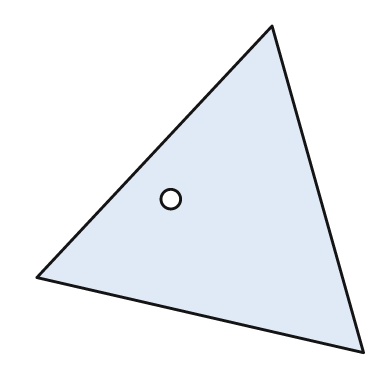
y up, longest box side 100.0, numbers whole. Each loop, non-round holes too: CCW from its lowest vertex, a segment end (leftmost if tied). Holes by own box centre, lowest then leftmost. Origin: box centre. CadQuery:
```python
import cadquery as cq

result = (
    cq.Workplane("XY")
    .moveTo(50.0, -50.0)
    .lineTo(22.0, 50.0)
    .lineTo(-50.0, -27.0)
    .close()
    .moveTo(-9.0, -3.0)
    .circle(3.0)
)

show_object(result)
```